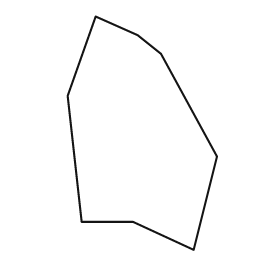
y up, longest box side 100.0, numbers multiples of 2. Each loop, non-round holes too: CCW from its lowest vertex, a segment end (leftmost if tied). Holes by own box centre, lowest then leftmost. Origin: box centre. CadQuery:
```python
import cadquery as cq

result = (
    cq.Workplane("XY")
    .moveTo(22.0, -50.0)
    .lineTo(32.0, -10.0)
    .lineTo(8.0, 34.0)
    .lineTo(-2.0, 42.0)
    .lineTo(-20.0, 50.0)
    .lineTo(-32.0, 16.0)
    .lineTo(-26.0, -38.0)
    .lineTo(-4.0, -38.0)
    .close()
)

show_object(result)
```